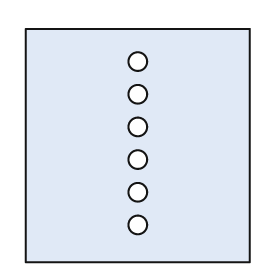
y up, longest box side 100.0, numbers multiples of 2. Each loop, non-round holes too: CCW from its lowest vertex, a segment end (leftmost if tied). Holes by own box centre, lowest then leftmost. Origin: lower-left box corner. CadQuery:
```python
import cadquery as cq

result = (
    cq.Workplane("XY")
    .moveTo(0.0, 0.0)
    .lineTo(96.0, 0.0)
    .lineTo(96.0, 100.0)
    .lineTo(0.0, 100.0)
    .close()
    .moveTo(48.0, 16.0)
    .circle(4.0)
    .moveTo(48.0, 30.0)
    .circle(4.0)
    .moveTo(48.0, 44.0)
    .circle(4.0)
    .moveTo(48.0, 58.0)
    .circle(4.0)
    .moveTo(48.0, 72.0)
    .circle(4.0)
    .moveTo(48.0, 86.0)
    .circle(4.0)
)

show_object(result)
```